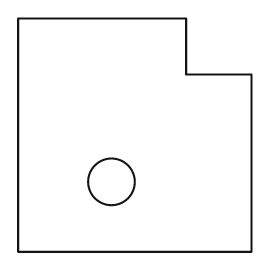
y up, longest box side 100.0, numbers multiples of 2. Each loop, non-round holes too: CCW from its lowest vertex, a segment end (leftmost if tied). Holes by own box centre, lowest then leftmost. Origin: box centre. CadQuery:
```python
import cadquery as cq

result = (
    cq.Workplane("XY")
    .moveTo(-50.0, -50.0)
    .lineTo(50.0, -50.0)
    .lineTo(50.0, 26.0)
    .lineTo(22.0, 26.0)
    .lineTo(22.0, 50.0)
    .lineTo(-50.0, 50.0)
    .close()
    .moveTo(-10.0, -20.0)
    .circle(10.0)
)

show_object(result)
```